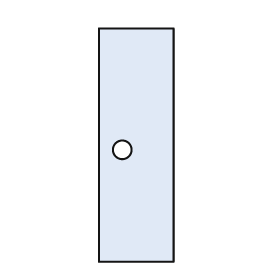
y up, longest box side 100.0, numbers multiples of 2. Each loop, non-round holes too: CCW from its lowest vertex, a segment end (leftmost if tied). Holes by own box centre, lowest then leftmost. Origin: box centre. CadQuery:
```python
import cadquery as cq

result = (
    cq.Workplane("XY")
    .moveTo(-16.0, -50.0)
    .lineTo(16.0, -50.0)
    .lineTo(16.0, 50.0)
    .lineTo(-16.0, 50.0)
    .close()
    .moveTo(-6.0, -2.0)
    .circle(4.0)
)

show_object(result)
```